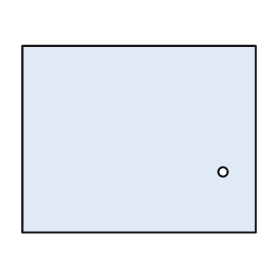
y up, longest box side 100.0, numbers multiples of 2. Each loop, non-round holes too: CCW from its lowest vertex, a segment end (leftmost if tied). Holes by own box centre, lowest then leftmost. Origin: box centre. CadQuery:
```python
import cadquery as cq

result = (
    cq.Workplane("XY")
    .moveTo(-50.0, -40.0)
    .lineTo(50.0, -40.0)
    .lineTo(50.0, 40.0)
    .lineTo(-50.0, 40.0)
    .close()
    .moveTo(36.0, -14.0)
    .circle(2.0)
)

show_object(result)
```